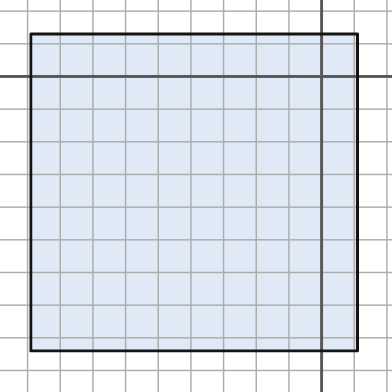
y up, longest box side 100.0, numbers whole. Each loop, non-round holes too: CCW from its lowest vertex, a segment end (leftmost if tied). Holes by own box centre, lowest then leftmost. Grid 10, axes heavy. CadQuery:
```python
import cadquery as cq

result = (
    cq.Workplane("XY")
    .moveTo(-89.0, -84.0)
    .lineTo(11.0, -84.0)
    .lineTo(11.0, 13.0)
    .lineTo(-89.0, 13.0)
    .close()
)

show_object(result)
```